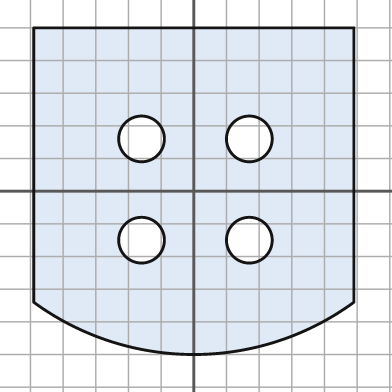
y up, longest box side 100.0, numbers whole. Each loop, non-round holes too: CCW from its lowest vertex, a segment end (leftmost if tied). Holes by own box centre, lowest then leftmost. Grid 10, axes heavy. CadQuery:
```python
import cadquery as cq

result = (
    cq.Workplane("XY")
    .moveTo(-49.0, -34.0)
    .threePointArc((0.0, -50.0), (49.0, -34.0))
    .lineTo(49.0, 50.0)
    .lineTo(-49.0, 50.0)
    .close()
    .moveTo(-16.0, -15.0)
    .circle(7.0)
    .moveTo(17.0, -15.0)
    .circle(7.0)
    .moveTo(-16.0, 16.0)
    .circle(7.0)
    .moveTo(17.0, 16.0)
    .circle(7.0)
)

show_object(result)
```